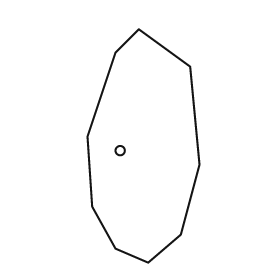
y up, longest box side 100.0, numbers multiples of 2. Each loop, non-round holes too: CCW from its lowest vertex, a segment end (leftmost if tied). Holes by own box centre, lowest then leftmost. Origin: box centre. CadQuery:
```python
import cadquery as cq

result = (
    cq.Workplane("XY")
    .moveTo(2.0, -50.0)
    .lineTo(16.0, -38.0)
    .lineTo(24.0, -8.0)
    .lineTo(20.0, 34.0)
    .lineTo(-2.0, 50.0)
    .lineTo(-12.0, 40.0)
    .lineTo(-24.0, 4.0)
    .lineTo(-22.0, -26.0)
    .lineTo(-12.0, -44.0)
    .close()
    .moveTo(-10.0, -2.0)
    .circle(2.0)
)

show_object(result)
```